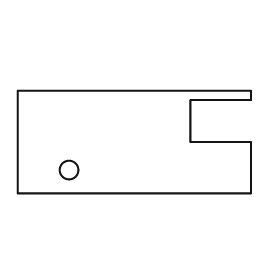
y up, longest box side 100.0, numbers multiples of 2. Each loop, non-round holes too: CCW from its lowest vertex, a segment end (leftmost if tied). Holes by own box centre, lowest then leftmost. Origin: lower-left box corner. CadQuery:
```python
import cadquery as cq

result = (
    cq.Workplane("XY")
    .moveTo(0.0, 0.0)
    .lineTo(100.0, 0.0)
    .lineTo(100.0, 22.0)
    .lineTo(74.0, 22.0)
    .lineTo(74.0, 40.0)
    .lineTo(100.0, 40.0)
    .lineTo(100.0, 44.0)
    .lineTo(0.0, 44.0)
    .close()
    .moveTo(22.0, 10.0)
    .circle(4.0)
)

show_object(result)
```